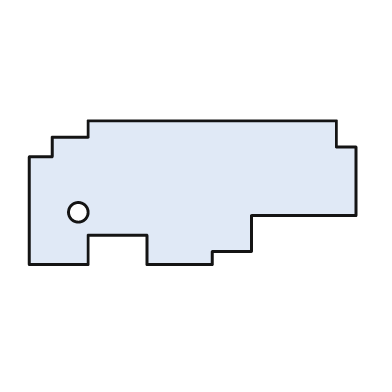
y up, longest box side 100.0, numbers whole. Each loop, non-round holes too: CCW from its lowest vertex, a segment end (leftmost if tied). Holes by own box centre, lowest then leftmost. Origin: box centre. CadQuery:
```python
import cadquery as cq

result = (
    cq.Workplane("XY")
    .moveTo(-50.0, -22.0)
    .lineTo(-32.0, -22.0)
    .lineTo(-32.0, -13.0)
    .lineTo(-14.0, -13.0)
    .lineTo(-14.0, -22.0)
    .lineTo(6.0, -22.0)
    .lineTo(6.0, -18.0)
    .lineTo(18.0, -18.0)
    .lineTo(18.0, -7.0)
    .lineTo(50.0, -7.0)
    .lineTo(50.0, 14.0)
    .lineTo(44.0, 14.0)
    .lineTo(44.0, 22.0)
    .lineTo(-32.0, 22.0)
    .lineTo(-32.0, 17.0)
    .lineTo(-43.0, 17.0)
    .lineTo(-43.0, 11.0)
    .lineTo(-50.0, 11.0)
    .close()
    .moveTo(-35.0, -6.0)
    .circle(3.0)
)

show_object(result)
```